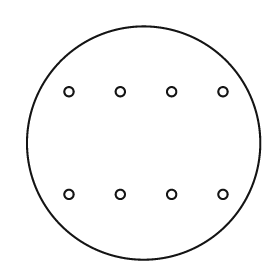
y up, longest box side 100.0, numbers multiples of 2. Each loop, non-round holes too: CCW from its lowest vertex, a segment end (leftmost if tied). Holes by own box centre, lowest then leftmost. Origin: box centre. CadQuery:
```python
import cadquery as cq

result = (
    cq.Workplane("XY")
    .moveTo(0.0, 0.0)
    .circle(50.0)
    .moveTo(-32.0, -22.0)
    .circle(2.0)
    .moveTo(-10.0, -22.0)
    .circle(2.0)
    .moveTo(12.0, -22.0)
    .circle(2.0)
    .moveTo(34.0, -22.0)
    .circle(2.0)
    .moveTo(-32.0, 22.0)
    .circle(2.0)
    .moveTo(-10.0, 22.0)
    .circle(2.0)
    .moveTo(12.0, 22.0)
    .circle(2.0)
    .moveTo(34.0, 22.0)
    .circle(2.0)
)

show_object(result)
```